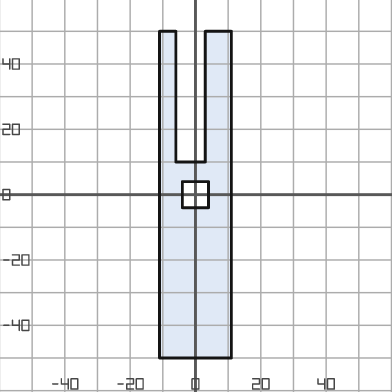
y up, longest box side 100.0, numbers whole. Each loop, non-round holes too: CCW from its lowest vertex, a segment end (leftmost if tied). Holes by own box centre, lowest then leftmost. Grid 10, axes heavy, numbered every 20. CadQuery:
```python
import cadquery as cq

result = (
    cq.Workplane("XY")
    .moveTo(-11.0, -50.0)
    .lineTo(11.0, -50.0)
    .lineTo(11.0, 50.0)
    .lineTo(3.0, 50.0)
    .lineTo(3.0, 10.0)
    .lineTo(-6.0, 10.0)
    .lineTo(-6.0, 50.0)
    .lineTo(-11.0, 50.0)
    .close()
    .moveTo(-4.0, -4.0)
    .lineTo(4.0, -4.0)
    .lineTo(4.0, 4.0)
    .lineTo(-4.0, 4.0)
    .close()
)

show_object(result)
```